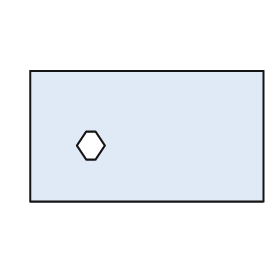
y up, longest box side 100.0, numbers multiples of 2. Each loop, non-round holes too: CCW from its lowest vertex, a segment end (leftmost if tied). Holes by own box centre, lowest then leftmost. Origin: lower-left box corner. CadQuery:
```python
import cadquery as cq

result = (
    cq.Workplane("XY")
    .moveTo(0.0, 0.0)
    .lineTo(100.0, 0.0)
    .lineTo(100.0, 56.0)
    .lineTo(0.0, 56.0)
    .close()
    .moveTo(24.0, 18.0)
    .lineTo(28.0, 18.0)
    .lineTo(32.0, 24.0)
    .lineTo(28.0, 30.0)
    .lineTo(24.0, 30.0)
    .lineTo(20.0, 24.0)
    .close()
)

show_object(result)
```